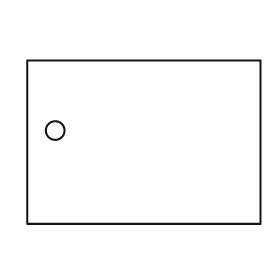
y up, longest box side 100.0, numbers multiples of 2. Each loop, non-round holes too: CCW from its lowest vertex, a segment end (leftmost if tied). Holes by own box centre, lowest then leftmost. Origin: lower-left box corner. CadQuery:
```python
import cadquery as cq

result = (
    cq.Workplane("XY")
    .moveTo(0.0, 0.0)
    .lineTo(100.0, 0.0)
    .lineTo(100.0, 70.0)
    .lineTo(0.0, 70.0)
    .close()
    .moveTo(12.0, 40.0)
    .circle(4.0)
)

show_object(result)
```